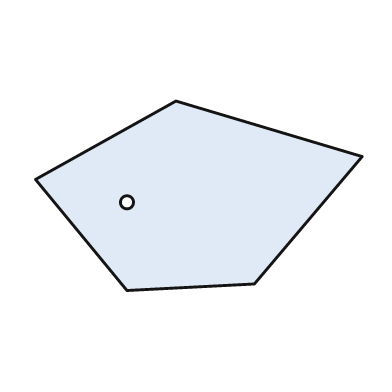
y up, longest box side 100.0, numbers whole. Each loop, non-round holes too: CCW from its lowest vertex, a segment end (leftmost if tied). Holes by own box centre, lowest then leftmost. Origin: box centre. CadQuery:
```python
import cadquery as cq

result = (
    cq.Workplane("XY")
    .moveTo(-22.0, -29.0)
    .lineTo(17.0, -27.0)
    .lineTo(50.0, 12.0)
    .lineTo(-7.0, 29.0)
    .lineTo(-50.0, 5.0)
    .close()
    .moveTo(-22.0, -2.0)
    .circle(2.0)
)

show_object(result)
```